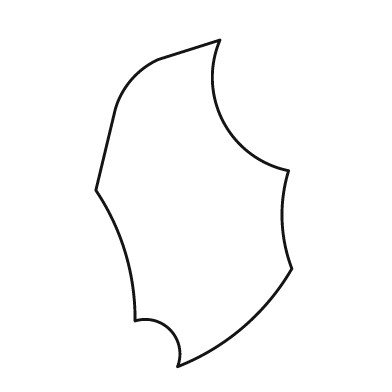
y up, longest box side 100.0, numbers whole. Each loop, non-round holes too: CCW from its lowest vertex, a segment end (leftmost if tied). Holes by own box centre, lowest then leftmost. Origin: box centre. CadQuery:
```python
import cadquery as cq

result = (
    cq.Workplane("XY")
    .moveTo(-5.0, -50.0)
    .threePointArc((15.0, -38.0), (30.0, -20.0))
    .threePointArc((27.0, -5.0), (29.0, 10.0))
    .threePointArc((9.0, 25.0), (8.0, 50.0))
    .lineTo(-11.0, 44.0)
    .threePointArc((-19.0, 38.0), (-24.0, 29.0))
    .lineTo(-30.0, 4.0)
    .threePointArc((-21.0, -15.0), (-18.0, -36.0))
    .threePointArc((-7.0, -39.0), (-5.0, -50.0))
    .close()
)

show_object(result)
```